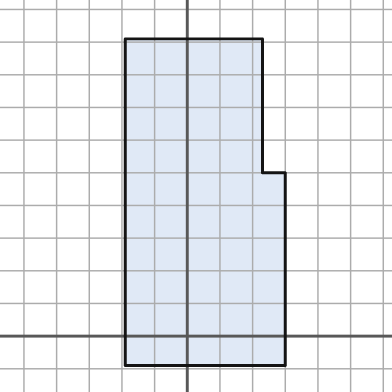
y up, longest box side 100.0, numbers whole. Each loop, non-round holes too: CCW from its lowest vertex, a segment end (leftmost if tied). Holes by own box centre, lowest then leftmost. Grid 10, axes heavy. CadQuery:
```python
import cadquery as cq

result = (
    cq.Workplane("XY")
    .moveTo(-19.0, -9.0)
    .lineTo(30.0, -9.0)
    .lineTo(30.0, 50.0)
    .lineTo(23.0, 50.0)
    .lineTo(23.0, 91.0)
    .lineTo(-19.0, 91.0)
    .close()
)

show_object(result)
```